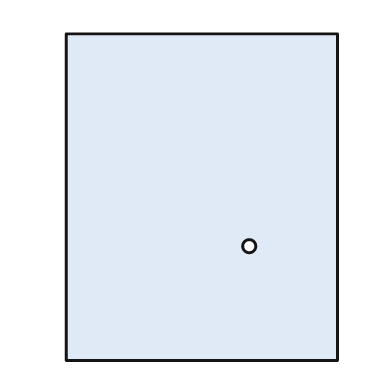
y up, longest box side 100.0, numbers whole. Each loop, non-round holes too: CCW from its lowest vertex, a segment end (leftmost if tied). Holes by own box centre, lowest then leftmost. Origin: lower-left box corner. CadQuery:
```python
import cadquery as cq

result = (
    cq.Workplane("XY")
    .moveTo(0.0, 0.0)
    .lineTo(83.0, 0.0)
    .lineTo(83.0, 100.0)
    .lineTo(0.0, 100.0)
    .close()
    .moveTo(56.0, 35.0)
    .circle(2.0)
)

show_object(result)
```